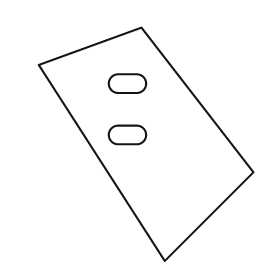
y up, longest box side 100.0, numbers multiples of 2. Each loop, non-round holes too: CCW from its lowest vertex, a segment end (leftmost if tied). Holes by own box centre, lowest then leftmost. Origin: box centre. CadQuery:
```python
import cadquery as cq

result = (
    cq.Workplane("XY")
    .moveTo(8.0, -50.0)
    .lineTo(46.0, -12.0)
    .lineTo(-2.0, 50.0)
    .lineTo(-46.0, 34.0)
    .close()
    .moveTo(-12.0, 0.0)
    .lineTo(-4.0, 0.0)
    .threePointArc((0.0, 4.0), (-4.0, 8.0))
    .lineTo(-12.0, 8.0)
    .threePointArc((-16.0, 4.0), (-12.0, 0.0))
    .close()
    .moveTo(-12.0, 22.0)
    .lineTo(-4.0, 22.0)
    .threePointArc((0.0, 26.0), (-4.0, 30.0))
    .lineTo(-12.0, 30.0)
    .threePointArc((-16.0, 26.0), (-12.0, 22.0))
    .close()
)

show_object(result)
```